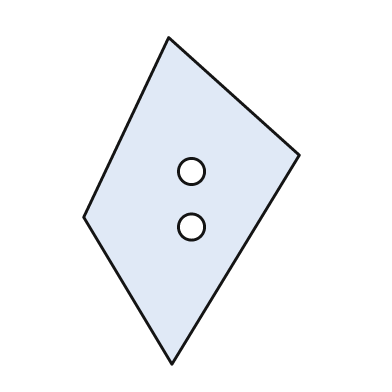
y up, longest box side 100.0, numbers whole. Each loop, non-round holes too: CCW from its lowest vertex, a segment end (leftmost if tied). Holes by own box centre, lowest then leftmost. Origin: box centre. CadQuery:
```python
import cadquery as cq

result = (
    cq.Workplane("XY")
    .moveTo(-6.0, -50.0)
    .lineTo(33.0, 14.0)
    .lineTo(-7.0, 50.0)
    .lineTo(-33.0, -5.0)
    .close()
    .moveTo(0.0, -8.0)
    .circle(4.0)
    .moveTo(0.0, 9.0)
    .circle(4.0)
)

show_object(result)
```